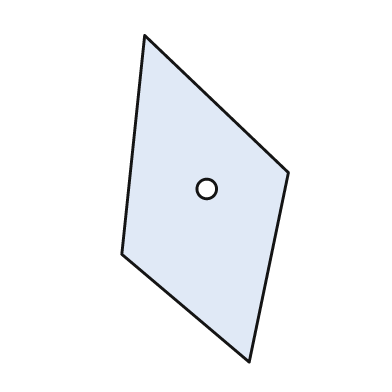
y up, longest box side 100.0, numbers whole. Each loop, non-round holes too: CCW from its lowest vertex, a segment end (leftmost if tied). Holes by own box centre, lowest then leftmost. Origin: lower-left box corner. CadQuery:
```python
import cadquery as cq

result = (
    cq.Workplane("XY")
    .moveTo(39.0, 0.0)
    .lineTo(51.0, 58.0)
    .lineTo(7.0, 100.0)
    .lineTo(0.0, 33.0)
    .close()
    .moveTo(26.0, 53.0)
    .circle(3.0)
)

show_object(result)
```